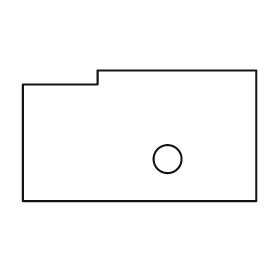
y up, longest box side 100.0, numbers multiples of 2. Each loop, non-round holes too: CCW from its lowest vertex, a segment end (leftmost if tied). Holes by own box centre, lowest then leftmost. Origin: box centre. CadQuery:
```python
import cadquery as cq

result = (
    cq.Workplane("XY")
    .moveTo(-50.0, -28.0)
    .lineTo(50.0, -28.0)
    .lineTo(50.0, 28.0)
    .lineTo(-18.0, 28.0)
    .lineTo(-18.0, 22.0)
    .lineTo(-50.0, 22.0)
    .close()
    .moveTo(12.0, -10.0)
    .circle(6.0)
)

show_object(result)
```